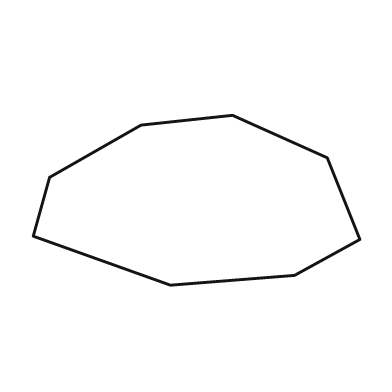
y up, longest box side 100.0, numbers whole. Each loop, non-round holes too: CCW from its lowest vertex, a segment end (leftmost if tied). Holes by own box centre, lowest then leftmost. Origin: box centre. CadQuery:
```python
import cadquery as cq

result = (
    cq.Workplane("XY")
    .moveTo(-8.0, -26.0)
    .lineTo(30.0, -23.0)
    .lineTo(50.0, -12.0)
    .lineTo(40.0, 13.0)
    .lineTo(11.0, 26.0)
    .lineTo(-17.0, 23.0)
    .lineTo(-45.0, 7.0)
    .lineTo(-50.0, -11.0)
    .close()
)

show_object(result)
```